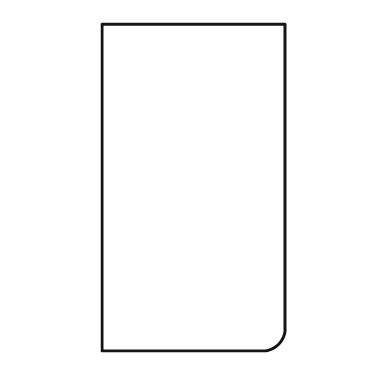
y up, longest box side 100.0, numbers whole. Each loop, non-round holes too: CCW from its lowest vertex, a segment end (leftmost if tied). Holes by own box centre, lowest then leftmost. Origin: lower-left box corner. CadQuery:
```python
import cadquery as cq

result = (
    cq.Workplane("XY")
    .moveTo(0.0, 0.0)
    .lineTo(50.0, 0.0)
    .threePointArc((54.0, 2.0), (56.0, 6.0))
    .lineTo(56.0, 100.0)
    .lineTo(0.0, 100.0)
    .close()
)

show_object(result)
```